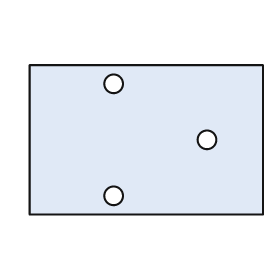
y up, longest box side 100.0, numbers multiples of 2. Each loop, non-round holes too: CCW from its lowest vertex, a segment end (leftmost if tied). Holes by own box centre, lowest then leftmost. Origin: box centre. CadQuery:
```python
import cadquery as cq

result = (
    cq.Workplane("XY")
    .moveTo(-50.0, -32.0)
    .lineTo(50.0, -32.0)
    .lineTo(50.0, 32.0)
    .lineTo(-50.0, 32.0)
    .close()
    .moveTo(-14.0, -24.0)
    .circle(4.0)
    .moveTo(26.0, 0.0)
    .circle(4.0)
    .moveTo(-14.0, 24.0)
    .circle(4.0)
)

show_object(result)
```